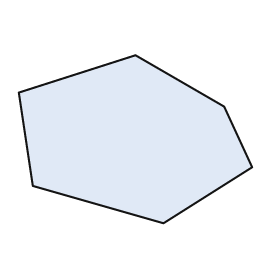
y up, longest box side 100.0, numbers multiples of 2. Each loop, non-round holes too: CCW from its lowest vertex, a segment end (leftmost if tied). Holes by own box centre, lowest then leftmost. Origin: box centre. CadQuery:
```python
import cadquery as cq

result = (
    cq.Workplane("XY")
    .moveTo(12.0, -36.0)
    .lineTo(50.0, -12.0)
    .lineTo(38.0, 14.0)
    .lineTo(0.0, 36.0)
    .lineTo(-50.0, 20.0)
    .lineTo(-44.0, -20.0)
    .close()
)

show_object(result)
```